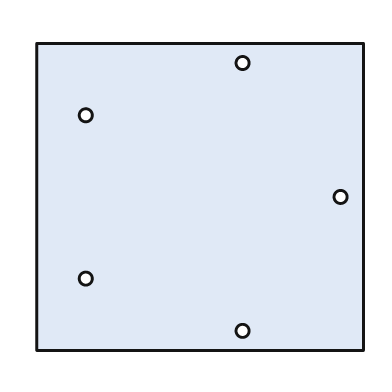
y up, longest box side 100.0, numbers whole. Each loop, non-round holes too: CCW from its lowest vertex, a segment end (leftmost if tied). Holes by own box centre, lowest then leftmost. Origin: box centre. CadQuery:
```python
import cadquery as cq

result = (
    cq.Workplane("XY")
    .moveTo(-50.0, -47.0)
    .lineTo(50.0, -47.0)
    .lineTo(50.0, 47.0)
    .lineTo(-50.0, 47.0)
    .close()
    .moveTo(13.0, -41.0)
    .circle(2.0)
    .moveTo(-35.0, -25.0)
    .circle(2.0)
    .moveTo(43.0, 0.0)
    .circle(2.0)
    .moveTo(-35.0, 25.0)
    .circle(2.0)
    .moveTo(13.0, 41.0)
    .circle(2.0)
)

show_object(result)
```